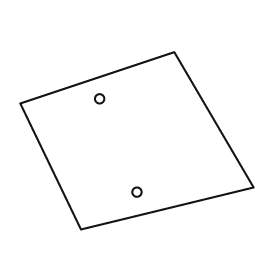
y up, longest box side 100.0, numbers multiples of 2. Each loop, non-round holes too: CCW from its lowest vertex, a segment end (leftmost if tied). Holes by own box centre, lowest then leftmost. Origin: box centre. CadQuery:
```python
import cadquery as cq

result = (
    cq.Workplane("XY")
    .moveTo(-24.0, -38.0)
    .lineTo(50.0, -20.0)
    .lineTo(16.0, 38.0)
    .lineTo(-50.0, 16.0)
    .close()
    .moveTo(0.0, -22.0)
    .circle(2.0)
    .moveTo(-16.0, 18.0)
    .circle(2.0)
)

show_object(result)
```